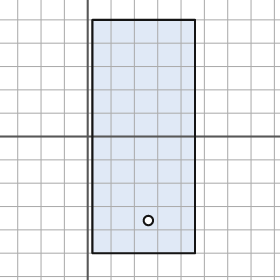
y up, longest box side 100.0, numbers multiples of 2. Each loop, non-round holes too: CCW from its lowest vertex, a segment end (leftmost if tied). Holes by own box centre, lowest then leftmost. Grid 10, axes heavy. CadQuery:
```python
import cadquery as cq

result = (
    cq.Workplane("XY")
    .moveTo(2.0, -50.0)
    .lineTo(46.0, -50.0)
    .lineTo(46.0, 50.0)
    .lineTo(2.0, 50.0)
    .close()
    .moveTo(26.0, -36.0)
    .circle(2.0)
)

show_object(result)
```